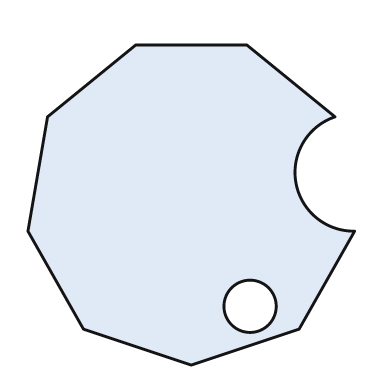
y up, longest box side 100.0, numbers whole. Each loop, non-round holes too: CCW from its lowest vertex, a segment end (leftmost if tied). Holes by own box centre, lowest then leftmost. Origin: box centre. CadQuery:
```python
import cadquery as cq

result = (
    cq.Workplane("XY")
    .moveTo(0.0, -49.0)
    .lineTo(33.0, -38.0)
    .lineTo(50.0, -8.0)
    .threePointArc((32.0, 7.0), (44.0, 27.0))
    .lineTo(17.0, 49.0)
    .lineTo(-17.0, 49.0)
    .lineTo(-44.0, 27.0)
    .lineTo(-50.0, -8.0)
    .lineTo(-33.0, -38.0)
    .close()
    .moveTo(18.0, -31.0)
    .circle(8.0)
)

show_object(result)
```